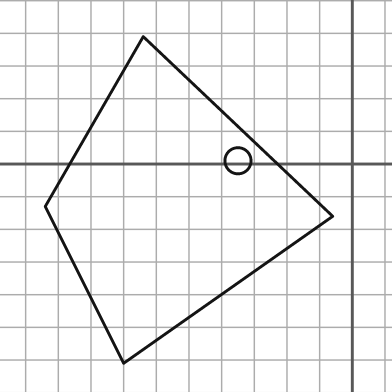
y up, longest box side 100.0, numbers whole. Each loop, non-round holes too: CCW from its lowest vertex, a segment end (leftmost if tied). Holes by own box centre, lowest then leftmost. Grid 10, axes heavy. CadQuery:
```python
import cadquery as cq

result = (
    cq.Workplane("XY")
    .moveTo(-70.0, -61.0)
    .lineTo(-6.0, -16.0)
    .lineTo(-64.0, 39.0)
    .lineTo(-94.0, -13.0)
    .close()
    .moveTo(-35.0, 1.0)
    .circle(4.0)
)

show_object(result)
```